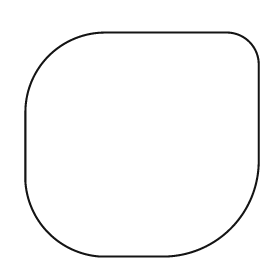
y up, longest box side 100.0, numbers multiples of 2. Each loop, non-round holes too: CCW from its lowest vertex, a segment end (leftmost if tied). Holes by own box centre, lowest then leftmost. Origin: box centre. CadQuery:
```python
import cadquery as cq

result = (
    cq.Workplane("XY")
    .moveTo(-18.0, -48.0)
    .lineTo(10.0, -48.0)
    .threePointArc((38.0, -36.0), (50.0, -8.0))
    .lineTo(50.0, 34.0)
    .threePointArc((46.0, 44.0), (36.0, 48.0))
    .lineTo(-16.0, 48.0)
    .threePointArc((-40.0, 38.0), (-50.0, 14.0))
    .lineTo(-50.0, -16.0)
    .threePointArc((-40.0, -38.0), (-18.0, -48.0))
    .close()
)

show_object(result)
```